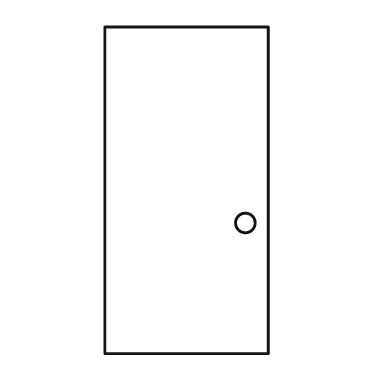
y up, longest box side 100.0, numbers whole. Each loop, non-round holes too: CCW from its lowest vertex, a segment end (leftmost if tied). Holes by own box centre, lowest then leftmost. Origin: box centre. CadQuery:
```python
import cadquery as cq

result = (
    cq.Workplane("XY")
    .moveTo(-25.0, -50.0)
    .lineTo(25.0, -50.0)
    .lineTo(25.0, 50.0)
    .lineTo(-25.0, 50.0)
    .close()
    .moveTo(18.0, -10.0)
    .circle(3.0)
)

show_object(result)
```